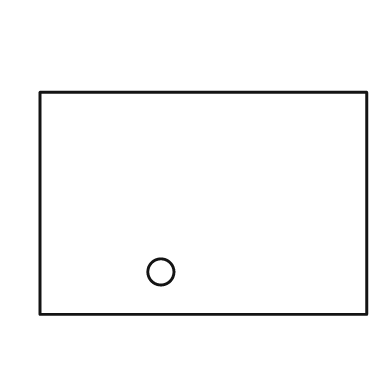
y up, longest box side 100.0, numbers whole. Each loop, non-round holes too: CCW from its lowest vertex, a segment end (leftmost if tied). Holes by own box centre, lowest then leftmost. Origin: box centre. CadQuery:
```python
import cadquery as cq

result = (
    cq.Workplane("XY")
    .moveTo(-50.0, -34.0)
    .lineTo(50.0, -34.0)
    .lineTo(50.0, 34.0)
    .lineTo(-50.0, 34.0)
    .close()
    .moveTo(-13.0, -21.0)
    .circle(4.0)
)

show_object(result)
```